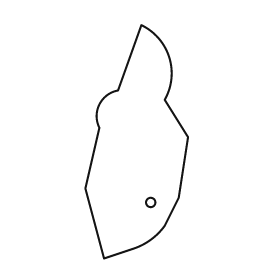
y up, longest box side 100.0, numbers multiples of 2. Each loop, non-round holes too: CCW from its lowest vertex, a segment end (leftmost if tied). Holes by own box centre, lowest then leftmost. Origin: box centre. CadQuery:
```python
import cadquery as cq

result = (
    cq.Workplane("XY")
    .moveTo(-14.0, -50.0)
    .lineTo(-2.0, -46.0)
    .threePointArc((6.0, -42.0), (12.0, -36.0))
    .lineTo(18.0, -24.0)
    .lineTo(22.0, 2.0)
    .lineTo(12.0, 18.0)
    .threePointArc((14.0, 36.0), (2.0, 50.0))
    .lineTo(-8.0, 22.0)
    .threePointArc((-16.0, 16.0), (-16.0, 6.0))
    .lineTo(-22.0, -20.0)
    .close()
    .moveTo(6.0, -26.0)
    .circle(2.0)
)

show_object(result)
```